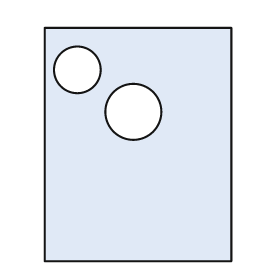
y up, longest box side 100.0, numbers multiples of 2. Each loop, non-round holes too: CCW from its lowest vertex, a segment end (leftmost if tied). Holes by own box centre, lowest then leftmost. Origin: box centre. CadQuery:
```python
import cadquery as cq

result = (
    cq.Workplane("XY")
    .moveTo(-40.0, -50.0)
    .lineTo(40.0, -50.0)
    .lineTo(40.0, 50.0)
    .lineTo(-40.0, 50.0)
    .close()
    .moveTo(-2.0, 14.0)
    .circle(12.0)
    .moveTo(-26.0, 32.0)
    .circle(10.0)
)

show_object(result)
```